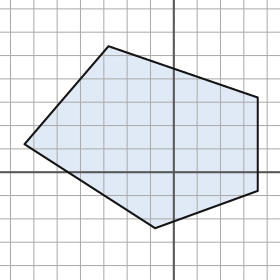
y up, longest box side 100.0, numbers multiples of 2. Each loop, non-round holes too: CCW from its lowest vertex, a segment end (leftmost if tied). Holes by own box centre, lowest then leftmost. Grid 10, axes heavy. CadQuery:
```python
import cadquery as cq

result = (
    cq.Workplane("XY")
    .moveTo(-8.0, -24.0)
    .lineTo(36.0, -8.0)
    .lineTo(36.0, 32.0)
    .lineTo(-28.0, 54.0)
    .lineTo(-64.0, 12.0)
    .close()
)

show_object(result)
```